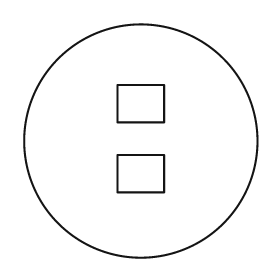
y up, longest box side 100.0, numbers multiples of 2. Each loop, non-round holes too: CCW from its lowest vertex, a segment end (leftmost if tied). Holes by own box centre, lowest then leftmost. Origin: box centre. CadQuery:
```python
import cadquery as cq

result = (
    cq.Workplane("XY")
    .moveTo(0.0, 0.0)
    .circle(50.0)
    .moveTo(-10.0, -22.0)
    .lineTo(10.0, -22.0)
    .lineTo(10.0, -6.0)
    .lineTo(-10.0, -6.0)
    .close()
    .moveTo(-10.0, 8.0)
    .lineTo(10.0, 8.0)
    .lineTo(10.0, 24.0)
    .lineTo(-10.0, 24.0)
    .close()
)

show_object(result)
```